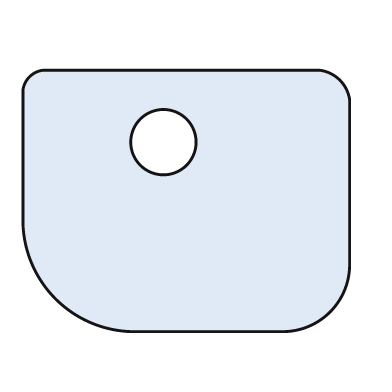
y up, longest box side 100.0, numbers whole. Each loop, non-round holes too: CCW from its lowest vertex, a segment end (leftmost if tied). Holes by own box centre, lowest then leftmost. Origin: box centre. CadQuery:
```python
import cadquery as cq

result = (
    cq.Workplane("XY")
    .moveTo(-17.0, -40.0)
    .lineTo(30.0, -40.0)
    .threePointArc((44.0, -34.0), (50.0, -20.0))
    .lineTo(50.0, 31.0)
    .threePointArc((47.0, 37.0), (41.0, 40.0))
    .lineTo(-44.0, 40.0)
    .threePointArc((-48.0, 38.0), (-50.0, 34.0))
    .lineTo(-50.0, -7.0)
    .threePointArc((-40.0, -30.0), (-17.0, -40.0))
    .close()
    .moveTo(-7.0, 18.0)
    .circle(10.0)
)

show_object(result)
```